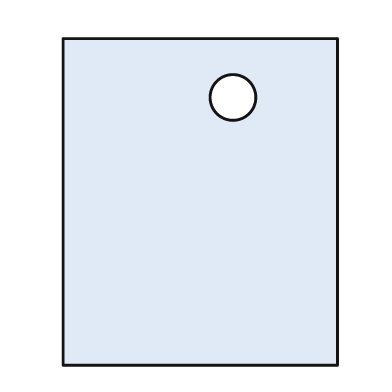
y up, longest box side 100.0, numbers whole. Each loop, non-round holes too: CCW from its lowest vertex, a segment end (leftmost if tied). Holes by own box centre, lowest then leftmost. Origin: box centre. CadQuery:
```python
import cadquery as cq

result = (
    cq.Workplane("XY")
    .moveTo(-42.0, -50.0)
    .lineTo(42.0, -50.0)
    .lineTo(42.0, 50.0)
    .lineTo(-42.0, 50.0)
    .close()
    .moveTo(10.0, 32.0)
    .circle(7.0)
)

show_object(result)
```